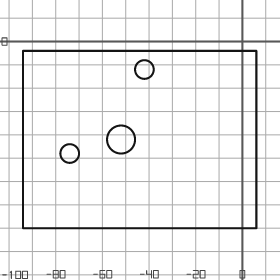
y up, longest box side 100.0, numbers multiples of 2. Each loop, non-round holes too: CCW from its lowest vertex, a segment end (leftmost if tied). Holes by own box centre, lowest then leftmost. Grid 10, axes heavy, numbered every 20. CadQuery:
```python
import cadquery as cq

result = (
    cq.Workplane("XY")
    .moveTo(-94.0, -80.0)
    .lineTo(6.0, -80.0)
    .lineTo(6.0, -4.0)
    .lineTo(-94.0, -4.0)
    .close()
    .moveTo(-74.0, -48.0)
    .circle(4.0)
    .moveTo(-52.0, -42.0)
    .circle(6.0)
    .moveTo(-42.0, -12.0)
    .circle(4.0)
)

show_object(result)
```